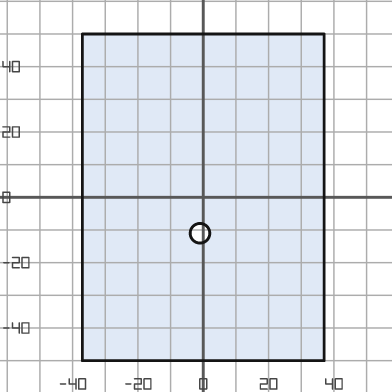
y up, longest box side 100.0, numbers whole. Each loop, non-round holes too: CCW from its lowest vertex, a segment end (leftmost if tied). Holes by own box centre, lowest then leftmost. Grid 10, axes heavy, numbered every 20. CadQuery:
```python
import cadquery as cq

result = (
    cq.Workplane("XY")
    .moveTo(-37.0, -50.0)
    .lineTo(37.0, -50.0)
    .lineTo(37.0, 50.0)
    .lineTo(-37.0, 50.0)
    .close()
    .moveTo(-1.0, -11.0)
    .circle(3.0)
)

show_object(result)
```